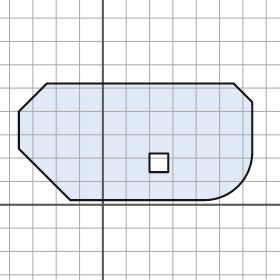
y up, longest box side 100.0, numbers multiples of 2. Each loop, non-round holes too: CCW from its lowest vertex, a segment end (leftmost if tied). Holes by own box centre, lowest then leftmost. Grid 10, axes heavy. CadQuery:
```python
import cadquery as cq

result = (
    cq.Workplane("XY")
    .moveTo(-14.0, 2.0)
    .lineTo(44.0, 2.0)
    .threePointArc((58.0, 8.0), (64.0, 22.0))
    .lineTo(64.0, 44.0)
    .lineTo(56.0, 52.0)
    .lineTo(-24.0, 52.0)
    .lineTo(-36.0, 40.0)
    .lineTo(-36.0, 24.0)
    .close()
    .moveTo(20.0, 14.0)
    .lineTo(28.0, 14.0)
    .lineTo(28.0, 22.0)
    .lineTo(20.0, 22.0)
    .close()
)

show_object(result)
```